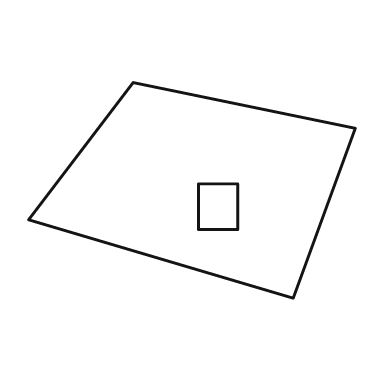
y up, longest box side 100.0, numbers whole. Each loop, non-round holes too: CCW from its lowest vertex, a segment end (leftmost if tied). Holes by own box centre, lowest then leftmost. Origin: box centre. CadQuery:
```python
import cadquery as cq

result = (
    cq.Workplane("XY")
    .moveTo(31.0, -33.0)
    .lineTo(50.0, 19.0)
    .lineTo(-18.0, 33.0)
    .lineTo(-50.0, -9.0)
    .close()
    .moveTo(2.0, -12.0)
    .lineTo(14.0, -12.0)
    .lineTo(14.0, 2.0)
    .lineTo(2.0, 2.0)
    .close()
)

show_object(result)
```